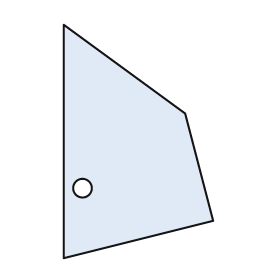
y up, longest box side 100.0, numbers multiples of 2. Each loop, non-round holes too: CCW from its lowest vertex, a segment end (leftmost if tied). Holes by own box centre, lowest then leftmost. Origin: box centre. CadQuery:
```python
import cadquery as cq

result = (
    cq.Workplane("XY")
    .moveTo(-32.0, -50.0)
    .lineTo(32.0, -34.0)
    .lineTo(20.0, 12.0)
    .lineTo(-32.0, 50.0)
    .close()
    .moveTo(-24.0, -20.0)
    .circle(4.0)
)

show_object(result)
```